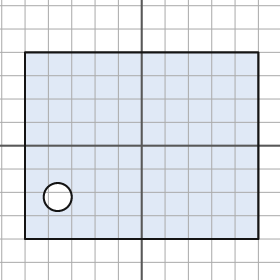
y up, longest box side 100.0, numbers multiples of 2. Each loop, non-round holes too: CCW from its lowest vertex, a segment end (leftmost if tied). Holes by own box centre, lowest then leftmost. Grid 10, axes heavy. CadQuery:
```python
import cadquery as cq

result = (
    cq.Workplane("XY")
    .moveTo(-50.0, -40.0)
    .lineTo(50.0, -40.0)
    .lineTo(50.0, 40.0)
    .lineTo(-50.0, 40.0)
    .close()
    .moveTo(-36.0, -22.0)
    .circle(6.0)
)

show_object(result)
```